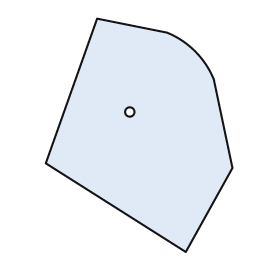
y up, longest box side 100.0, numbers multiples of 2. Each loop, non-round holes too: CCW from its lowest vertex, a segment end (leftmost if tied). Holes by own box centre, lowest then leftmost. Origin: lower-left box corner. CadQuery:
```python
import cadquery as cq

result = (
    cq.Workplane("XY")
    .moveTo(60.0, 0.0)
    .lineTo(80.0, 36.0)
    .lineTo(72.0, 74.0)
    .threePointArc((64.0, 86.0), (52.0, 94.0))
    .lineTo(22.0, 100.0)
    .lineTo(0.0, 38.0)
    .close()
    .moveTo(36.0, 60.0)
    .circle(2.0)
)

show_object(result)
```